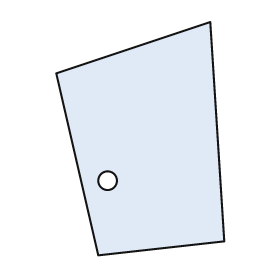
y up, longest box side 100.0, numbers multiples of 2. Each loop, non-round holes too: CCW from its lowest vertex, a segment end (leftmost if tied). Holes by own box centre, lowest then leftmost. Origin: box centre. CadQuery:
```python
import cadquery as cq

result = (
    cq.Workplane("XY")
    .moveTo(-18.0, -50.0)
    .lineTo(36.0, -44.0)
    .lineTo(30.0, 50.0)
    .lineTo(-36.0, 28.0)
    .close()
    .moveTo(-14.0, -18.0)
    .circle(4.0)
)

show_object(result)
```